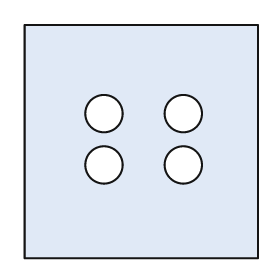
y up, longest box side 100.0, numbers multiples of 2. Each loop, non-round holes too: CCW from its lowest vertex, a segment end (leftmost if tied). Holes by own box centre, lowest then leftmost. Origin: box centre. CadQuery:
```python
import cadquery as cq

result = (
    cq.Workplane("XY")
    .moveTo(-50.0, -50.0)
    .lineTo(50.0, -50.0)
    .lineTo(50.0, 50.0)
    .lineTo(-50.0, 50.0)
    .close()
    .moveTo(-16.0, -10.0)
    .circle(8.0)
    .moveTo(18.0, -10.0)
    .circle(8.0)
    .moveTo(-16.0, 12.0)
    .circle(8.0)
    .moveTo(18.0, 12.0)
    .circle(8.0)
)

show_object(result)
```